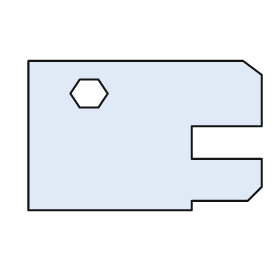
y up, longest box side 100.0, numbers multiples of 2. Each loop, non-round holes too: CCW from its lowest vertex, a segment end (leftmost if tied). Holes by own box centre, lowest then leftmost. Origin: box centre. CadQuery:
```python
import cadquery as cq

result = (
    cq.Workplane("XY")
    .moveTo(-50.0, -32.0)
    .lineTo(20.0, -32.0)
    .lineTo(20.0, -28.0)
    .lineTo(44.0, -28.0)
    .lineTo(50.0, -22.0)
    .lineTo(50.0, -10.0)
    .lineTo(20.0, -10.0)
    .lineTo(20.0, 4.0)
    .lineTo(50.0, 4.0)
    .lineTo(50.0, 26.0)
    .lineTo(42.0, 32.0)
    .lineTo(-50.0, 32.0)
    .close()
    .moveTo(-28.0, 12.0)
    .lineTo(-20.0, 12.0)
    .lineTo(-16.0, 18.0)
    .lineTo(-20.0, 24.0)
    .lineTo(-28.0, 24.0)
    .lineTo(-32.0, 18.0)
    .close()
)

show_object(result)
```